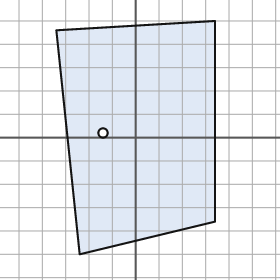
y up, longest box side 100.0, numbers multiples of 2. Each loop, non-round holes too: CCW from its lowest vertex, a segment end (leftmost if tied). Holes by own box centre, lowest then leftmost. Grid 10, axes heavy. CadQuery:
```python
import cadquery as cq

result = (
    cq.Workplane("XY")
    .moveTo(-24.0, -50.0)
    .lineTo(34.0, -36.0)
    .lineTo(34.0, 50.0)
    .lineTo(-34.0, 46.0)
    .close()
    .moveTo(-14.0, 2.0)
    .circle(2.0)
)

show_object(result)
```